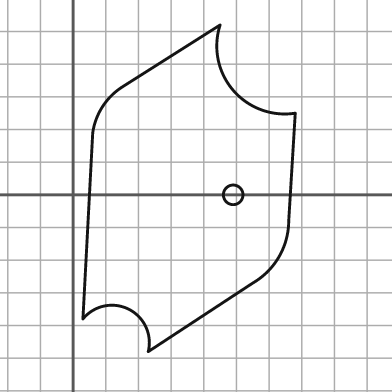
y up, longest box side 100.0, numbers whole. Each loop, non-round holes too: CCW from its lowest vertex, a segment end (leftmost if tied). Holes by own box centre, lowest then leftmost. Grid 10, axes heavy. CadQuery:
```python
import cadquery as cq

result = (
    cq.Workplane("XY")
    .moveTo(23.0, -48.0)
    .lineTo(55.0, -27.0)
    .threePointArc((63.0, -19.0), (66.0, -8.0))
    .lineTo(68.0, 25.0)
    .threePointArc((49.0, 32.0), (45.0, 52.0))
    .lineTo(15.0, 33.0)
    .threePointArc((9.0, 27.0), (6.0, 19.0))
    .lineTo(3.0, -38.0)
    .threePointArc((17.0, -35.0), (23.0, -48.0))
    .close()
    .moveTo(49.0, 0.0)
    .circle(3.0)
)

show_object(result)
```